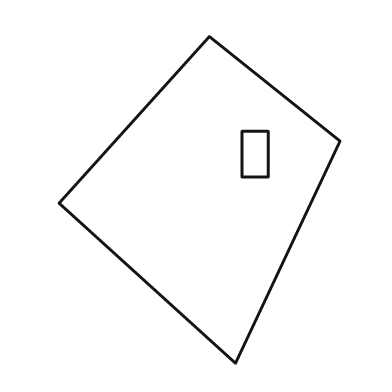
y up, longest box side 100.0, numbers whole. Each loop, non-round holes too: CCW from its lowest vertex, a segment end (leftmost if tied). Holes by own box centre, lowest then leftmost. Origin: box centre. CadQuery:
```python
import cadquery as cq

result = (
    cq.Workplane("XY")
    .moveTo(11.0, -50.0)
    .lineTo(43.0, 18.0)
    .lineTo(3.0, 50.0)
    .lineTo(-43.0, -1.0)
    .close()
    .moveTo(13.0, 7.0)
    .lineTo(21.0, 7.0)
    .lineTo(21.0, 21.0)
    .lineTo(13.0, 21.0)
    .close()
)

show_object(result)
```